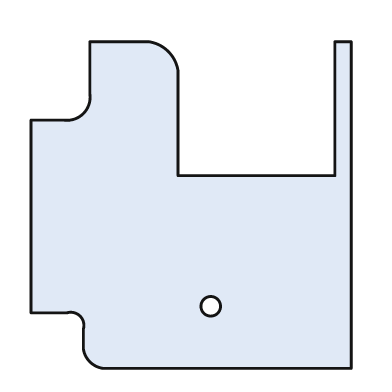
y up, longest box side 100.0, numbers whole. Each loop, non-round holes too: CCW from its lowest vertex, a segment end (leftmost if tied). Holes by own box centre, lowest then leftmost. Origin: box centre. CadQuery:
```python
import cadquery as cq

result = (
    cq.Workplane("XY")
    .moveTo(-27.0, -50.0)
    .lineTo(49.0, -50.0)
    .lineTo(49.0, 50.0)
    .lineTo(44.0, 50.0)
    .lineTo(44.0, 9.0)
    .lineTo(-4.0, 9.0)
    .lineTo(-4.0, 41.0)
    .threePointArc((-7.0, 47.0), (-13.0, 50.0))
    .lineTo(-31.0, 50.0)
    .lineTo(-31.0, 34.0)
    .threePointArc((-33.0, 28.0), (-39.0, 26.0))
    .lineTo(-49.0, 26.0)
    .lineTo(-49.0, -33.0)
    .lineTo(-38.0, -33.0)
    .threePointArc((-34.0, -34.0), (-33.0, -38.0))
    .lineTo(-33.0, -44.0)
    .threePointArc((-31.0, -48.0), (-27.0, -50.0))
    .close()
    .moveTo(6.0, -31.0)
    .circle(3.0)
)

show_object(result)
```